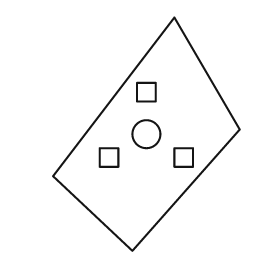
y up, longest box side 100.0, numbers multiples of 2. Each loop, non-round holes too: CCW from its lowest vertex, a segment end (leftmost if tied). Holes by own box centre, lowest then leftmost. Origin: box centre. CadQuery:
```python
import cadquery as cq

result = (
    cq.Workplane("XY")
    .moveTo(-6.0, -50.0)
    .lineTo(40.0, 2.0)
    .lineTo(12.0, 50.0)
    .lineTo(-40.0, -18.0)
    .close()
    .moveTo(-20.0, -14.0)
    .lineTo(-12.0, -14.0)
    .lineTo(-12.0, -6.0)
    .lineTo(-20.0, -6.0)
    .close()
    .moveTo(12.0, -14.0)
    .lineTo(20.0, -14.0)
    .lineTo(20.0, -6.0)
    .lineTo(12.0, -6.0)
    .close()
    .moveTo(0.0, 0.0)
    .circle(6.0)
    .moveTo(-4.0, 14.0)
    .lineTo(4.0, 14.0)
    .lineTo(4.0, 22.0)
    .lineTo(-4.0, 22.0)
    .close()
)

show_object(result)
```